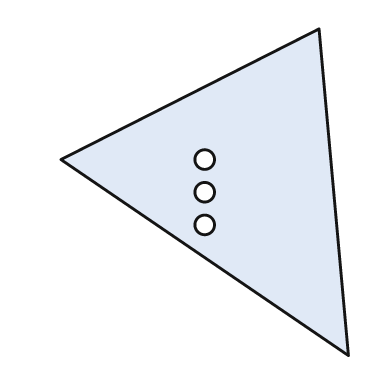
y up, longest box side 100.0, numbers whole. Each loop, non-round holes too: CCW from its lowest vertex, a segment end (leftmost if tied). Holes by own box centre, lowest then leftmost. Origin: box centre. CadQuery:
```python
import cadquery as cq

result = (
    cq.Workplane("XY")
    .moveTo(44.0, -50.0)
    .lineTo(35.0, 50.0)
    .lineTo(-44.0, 10.0)
    .close()
    .moveTo(0.0, -10.0)
    .circle(3.0)
    .moveTo(0.0, 0.0)
    .circle(3.0)
    .moveTo(0.0, 10.0)
    .circle(3.0)
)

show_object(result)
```